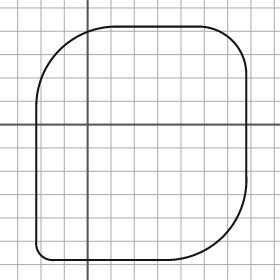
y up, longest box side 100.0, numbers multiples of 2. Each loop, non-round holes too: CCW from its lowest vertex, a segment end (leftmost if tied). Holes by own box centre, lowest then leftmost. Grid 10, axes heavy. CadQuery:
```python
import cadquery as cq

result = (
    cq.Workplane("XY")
    .moveTo(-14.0, -58.0)
    .lineTo(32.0, -58.0)
    .threePointArc((58.0, -48.0), (68.0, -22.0))
    .lineTo(68.0, 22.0)
    .threePointArc((62.0, 36.0), (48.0, 42.0))
    .lineTo(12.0, 42.0)
    .threePointArc((-12.0, 32.0), (-22.0, 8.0))
    .lineTo(-22.0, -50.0)
    .threePointArc((-20.0, -56.0), (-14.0, -58.0))
    .close()
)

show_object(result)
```